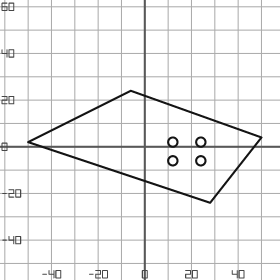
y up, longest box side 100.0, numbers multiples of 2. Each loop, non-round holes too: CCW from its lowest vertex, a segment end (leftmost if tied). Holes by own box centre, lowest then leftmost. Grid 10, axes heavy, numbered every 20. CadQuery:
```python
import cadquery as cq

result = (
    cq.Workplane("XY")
    .moveTo(28.0, -24.0)
    .lineTo(50.0, 4.0)
    .lineTo(-6.0, 24.0)
    .lineTo(-50.0, 2.0)
    .close()
    .moveTo(12.0, -6.0)
    .circle(2.0)
    .moveTo(24.0, -6.0)
    .circle(2.0)
    .moveTo(12.0, 2.0)
    .circle(2.0)
    .moveTo(24.0, 2.0)
    .circle(2.0)
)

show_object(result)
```